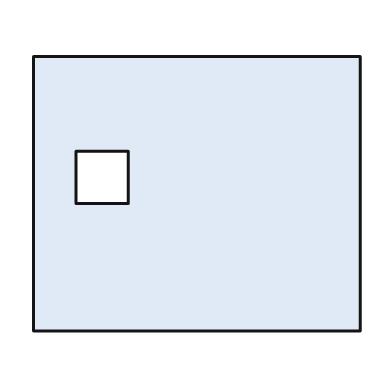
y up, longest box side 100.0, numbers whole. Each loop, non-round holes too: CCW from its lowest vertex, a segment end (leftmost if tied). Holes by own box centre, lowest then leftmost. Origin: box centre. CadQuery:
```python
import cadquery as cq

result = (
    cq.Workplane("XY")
    .moveTo(-50.0, -42.0)
    .lineTo(50.0, -42.0)
    .lineTo(50.0, 42.0)
    .lineTo(-50.0, 42.0)
    .close()
    .moveTo(-37.0, -3.0)
    .lineTo(-21.0, -3.0)
    .lineTo(-21.0, 13.0)
    .lineTo(-37.0, 13.0)
    .close()
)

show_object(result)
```